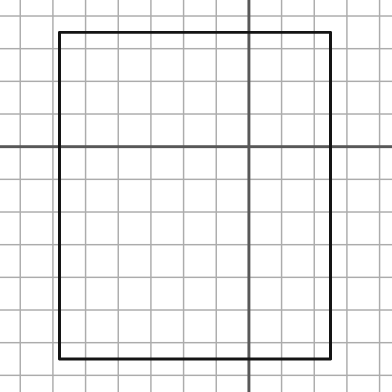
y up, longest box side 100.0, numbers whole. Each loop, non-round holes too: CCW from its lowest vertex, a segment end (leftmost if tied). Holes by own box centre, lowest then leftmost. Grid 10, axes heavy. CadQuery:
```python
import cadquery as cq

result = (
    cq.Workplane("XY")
    .moveTo(-58.0, -65.0)
    .lineTo(25.0, -65.0)
    .lineTo(25.0, 35.0)
    .lineTo(-58.0, 35.0)
    .close()
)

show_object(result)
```